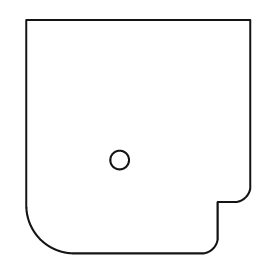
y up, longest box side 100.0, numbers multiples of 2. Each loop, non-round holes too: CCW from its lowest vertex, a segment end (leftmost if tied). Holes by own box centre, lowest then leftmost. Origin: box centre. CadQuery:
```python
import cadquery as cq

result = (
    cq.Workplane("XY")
    .moveTo(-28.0, -50.0)
    .lineTo(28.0, -50.0)
    .threePointArc((32.0, -48.0), (34.0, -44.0))
    .lineTo(34.0, -28.0)
    .lineTo(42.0, -28.0)
    .threePointArc((46.0, -26.0), (48.0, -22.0))
    .lineTo(48.0, 50.0)
    .lineTo(-48.0, 50.0)
    .lineTo(-48.0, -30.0)
    .threePointArc((-42.0, -44.0), (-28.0, -50.0))
    .close()
    .moveTo(-8.0, -10.0)
    .circle(4.0)
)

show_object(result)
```